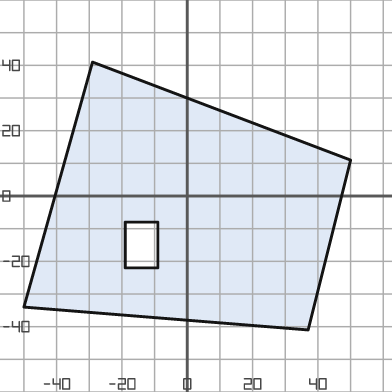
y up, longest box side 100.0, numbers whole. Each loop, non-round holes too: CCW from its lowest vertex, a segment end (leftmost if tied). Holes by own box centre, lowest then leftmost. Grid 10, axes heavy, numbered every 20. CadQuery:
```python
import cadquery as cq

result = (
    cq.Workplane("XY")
    .moveTo(37.0, -41.0)
    .lineTo(50.0, 11.0)
    .lineTo(-29.0, 41.0)
    .lineTo(-50.0, -34.0)
    .close()
    .moveTo(-19.0, -22.0)
    .lineTo(-9.0, -22.0)
    .lineTo(-9.0, -8.0)
    .lineTo(-19.0, -8.0)
    .close()
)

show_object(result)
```